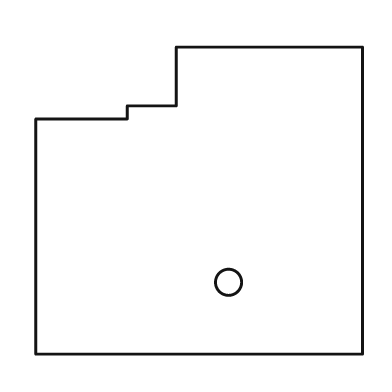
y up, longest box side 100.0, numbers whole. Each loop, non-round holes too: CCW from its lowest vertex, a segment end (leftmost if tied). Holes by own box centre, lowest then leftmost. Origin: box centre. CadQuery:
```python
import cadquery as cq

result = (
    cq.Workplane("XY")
    .moveTo(-50.0, -47.0)
    .lineTo(50.0, -47.0)
    .lineTo(50.0, 47.0)
    .lineTo(-7.0, 47.0)
    .lineTo(-7.0, 29.0)
    .lineTo(-22.0, 29.0)
    .lineTo(-22.0, 25.0)
    .lineTo(-50.0, 25.0)
    .close()
    .moveTo(9.0, -25.0)
    .circle(4.0)
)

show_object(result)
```